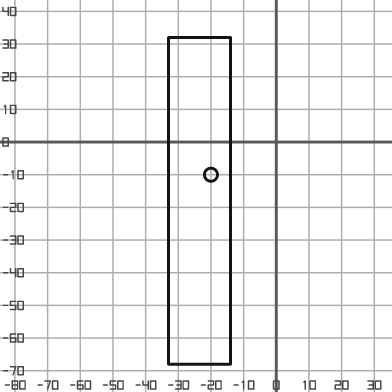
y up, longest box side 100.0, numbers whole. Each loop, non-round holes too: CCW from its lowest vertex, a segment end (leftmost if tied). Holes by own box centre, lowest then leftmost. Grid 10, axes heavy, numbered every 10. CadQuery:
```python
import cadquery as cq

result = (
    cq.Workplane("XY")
    .moveTo(-33.0, -68.0)
    .lineTo(-14.0, -68.0)
    .lineTo(-14.0, 32.0)
    .lineTo(-33.0, 32.0)
    .close()
    .moveTo(-20.0, -10.0)
    .circle(2.0)
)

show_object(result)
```